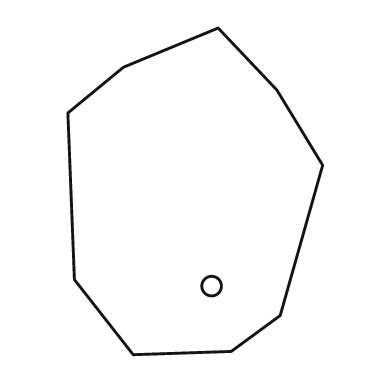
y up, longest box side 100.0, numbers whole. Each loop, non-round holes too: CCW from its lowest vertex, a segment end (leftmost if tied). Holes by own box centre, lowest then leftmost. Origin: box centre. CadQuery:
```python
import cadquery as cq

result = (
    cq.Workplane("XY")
    .moveTo(-19.0, -50.0)
    .lineTo(11.0, -49.0)
    .lineTo(26.0, -38.0)
    .lineTo(39.0, 8.0)
    .lineTo(25.0, 31.0)
    .lineTo(7.0, 50.0)
    .lineTo(-22.0, 38.0)
    .lineTo(-39.0, 24.0)
    .lineTo(-37.0, -27.0)
    .close()
    .moveTo(5.0, -29.0)
    .circle(3.0)
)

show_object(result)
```